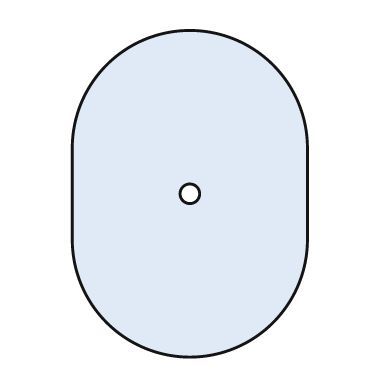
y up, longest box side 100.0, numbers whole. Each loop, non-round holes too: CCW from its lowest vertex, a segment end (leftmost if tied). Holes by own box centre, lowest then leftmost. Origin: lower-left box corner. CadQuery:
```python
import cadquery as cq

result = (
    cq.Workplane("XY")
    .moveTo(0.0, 36.0)
    .threePointArc((36.0, 0.0), (72.0, 36.0))
    .lineTo(72.0, 64.0)
    .threePointArc((36.0, 100.0), (0.0, 64.0))
    .close()
    .moveTo(36.0, 50.0)
    .circle(3.0)
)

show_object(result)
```